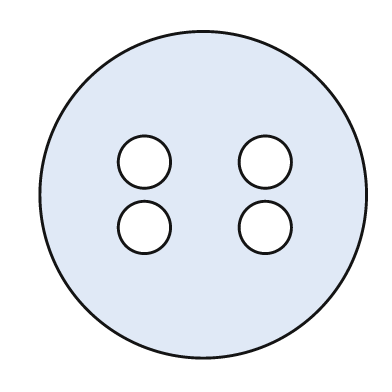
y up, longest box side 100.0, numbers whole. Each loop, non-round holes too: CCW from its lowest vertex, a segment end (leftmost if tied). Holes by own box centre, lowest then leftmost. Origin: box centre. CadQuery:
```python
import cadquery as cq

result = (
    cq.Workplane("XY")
    .moveTo(0.0, 0.0)
    .circle(50.0)
    .moveTo(-18.0, -10.0)
    .circle(8.0)
    .moveTo(19.0, -10.0)
    .circle(8.0)
    .moveTo(-18.0, 10.0)
    .circle(8.0)
    .moveTo(19.0, 10.0)
    .circle(8.0)
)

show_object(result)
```